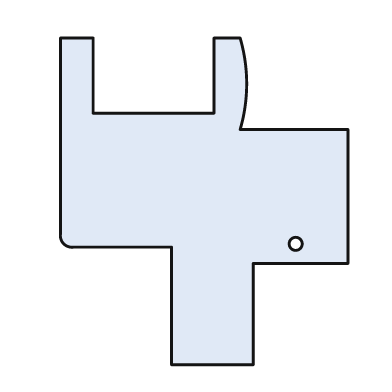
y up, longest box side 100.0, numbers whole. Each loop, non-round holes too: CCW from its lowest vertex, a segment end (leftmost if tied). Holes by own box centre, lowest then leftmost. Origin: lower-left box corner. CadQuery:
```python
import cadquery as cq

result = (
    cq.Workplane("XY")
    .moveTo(34.0, 0.0)
    .lineTo(59.0, 0.0)
    .lineTo(59.0, 31.0)
    .lineTo(88.0, 31.0)
    .lineTo(88.0, 72.0)
    .lineTo(55.0, 72.0)
    .threePointArc((57.0, 86.0), (55.0, 100.0))
    .lineTo(47.0, 100.0)
    .lineTo(47.0, 77.0)
    .lineTo(10.0, 77.0)
    .lineTo(10.0, 100.0)
    .lineTo(0.0, 100.0)
    .lineTo(0.0, 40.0)
    .threePointArc((1.0, 37.0), (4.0, 36.0))
    .lineTo(34.0, 36.0)
    .close()
    .moveTo(72.0, 37.0)
    .circle(2.0)
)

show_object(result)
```